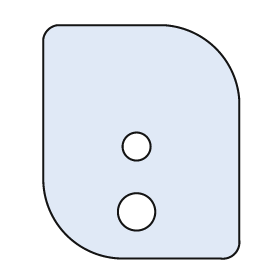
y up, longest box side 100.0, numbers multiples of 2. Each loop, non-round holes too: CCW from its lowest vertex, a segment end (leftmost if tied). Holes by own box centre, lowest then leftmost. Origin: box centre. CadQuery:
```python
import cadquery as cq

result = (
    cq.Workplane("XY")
    .moveTo(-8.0, -50.0)
    .lineTo(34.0, -50.0)
    .threePointArc((40.0, -48.0), (42.0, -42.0))
    .lineTo(42.0, 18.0)
    .threePointArc((32.0, 40.0), (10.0, 50.0))
    .lineTo(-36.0, 50.0)
    .threePointArc((-40.0, 48.0), (-42.0, 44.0))
    .lineTo(-42.0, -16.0)
    .threePointArc((-32.0, -40.0), (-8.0, -50.0))
    .close()
    .moveTo(-2.0, -30.0)
    .circle(8.0)
    .moveTo(-2.0, -2.0)
    .circle(6.0)
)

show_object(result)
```